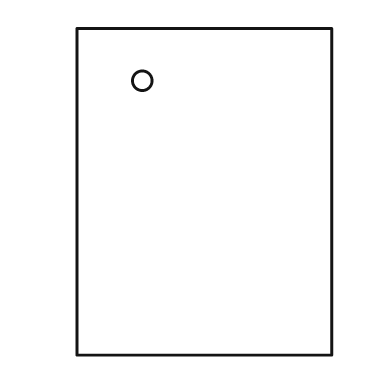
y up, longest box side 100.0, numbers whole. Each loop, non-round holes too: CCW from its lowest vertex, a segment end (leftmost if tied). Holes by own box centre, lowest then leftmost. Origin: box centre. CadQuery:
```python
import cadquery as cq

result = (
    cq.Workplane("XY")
    .moveTo(-39.0, -50.0)
    .lineTo(39.0, -50.0)
    .lineTo(39.0, 50.0)
    .lineTo(-39.0, 50.0)
    .close()
    .moveTo(-19.0, 34.0)
    .circle(3.0)
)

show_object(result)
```